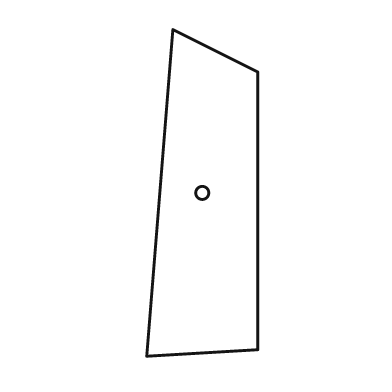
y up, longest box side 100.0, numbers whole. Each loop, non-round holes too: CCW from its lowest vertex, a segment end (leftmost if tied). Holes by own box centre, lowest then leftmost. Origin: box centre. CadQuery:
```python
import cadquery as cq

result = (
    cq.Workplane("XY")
    .moveTo(-17.0, -50.0)
    .lineTo(17.0, -48.0)
    .lineTo(17.0, 37.0)
    .lineTo(-9.0, 50.0)
    .close()
    .moveTo(0.0, 0.0)
    .circle(2.0)
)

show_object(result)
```